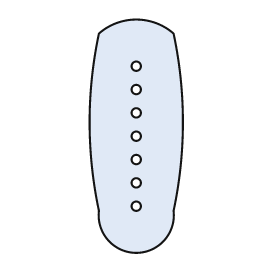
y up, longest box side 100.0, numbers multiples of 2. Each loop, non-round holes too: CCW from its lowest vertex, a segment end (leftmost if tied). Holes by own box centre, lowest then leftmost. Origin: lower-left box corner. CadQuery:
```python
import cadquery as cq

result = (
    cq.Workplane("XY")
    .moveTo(4.0, 18.0)
    .threePointArc((20.0, 0.0), (36.0, 18.0))
    .threePointArc((40.0, 56.0), (36.0, 94.0))
    .threePointArc((20.0, 100.0), (4.0, 94.0))
    .threePointArc((0.0, 56.0), (4.0, 18.0))
    .close()
    .moveTo(20.0, 20.0)
    .circle(2.0)
    .moveTo(20.0, 30.0)
    .circle(2.0)
    .moveTo(20.0, 40.0)
    .circle(2.0)
    .moveTo(20.0, 50.0)
    .circle(2.0)
    .moveTo(20.0, 60.0)
    .circle(2.0)
    .moveTo(20.0, 70.0)
    .circle(2.0)
    .moveTo(20.0, 80.0)
    .circle(2.0)
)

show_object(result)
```